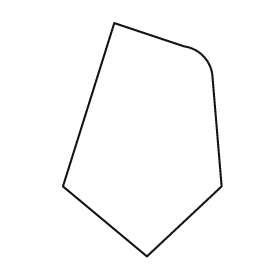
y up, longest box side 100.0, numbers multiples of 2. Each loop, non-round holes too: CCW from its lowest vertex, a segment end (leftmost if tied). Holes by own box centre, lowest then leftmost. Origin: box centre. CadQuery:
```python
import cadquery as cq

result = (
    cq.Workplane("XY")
    .moveTo(2.0, -50.0)
    .lineTo(34.0, -20.0)
    .lineTo(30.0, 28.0)
    .threePointArc((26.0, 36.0), (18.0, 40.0))
    .lineTo(-12.0, 50.0)
    .lineTo(-34.0, -20.0)
    .close()
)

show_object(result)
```